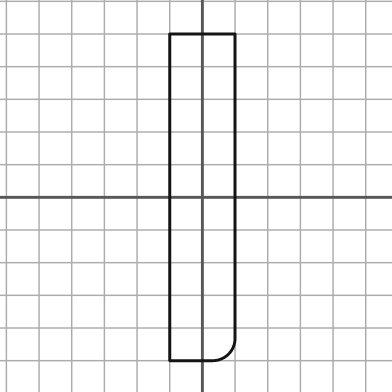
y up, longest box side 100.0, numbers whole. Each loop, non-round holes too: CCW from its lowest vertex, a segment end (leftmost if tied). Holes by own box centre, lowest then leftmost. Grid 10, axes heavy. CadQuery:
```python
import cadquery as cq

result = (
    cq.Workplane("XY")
    .moveTo(-10.0, -50.0)
    .lineTo(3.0, -50.0)
    .threePointArc((8.0, -48.0), (10.0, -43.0))
    .lineTo(10.0, 50.0)
    .lineTo(-10.0, 50.0)
    .close()
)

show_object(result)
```